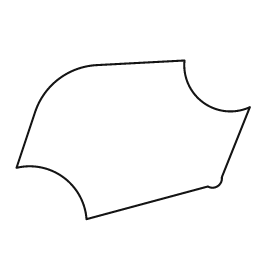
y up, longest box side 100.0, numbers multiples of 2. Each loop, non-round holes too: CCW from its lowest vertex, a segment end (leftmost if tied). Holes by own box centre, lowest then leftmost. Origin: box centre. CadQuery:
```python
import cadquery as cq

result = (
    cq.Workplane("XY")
    .moveTo(-20.0, -34.0)
    .lineTo(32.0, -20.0)
    .threePointArc((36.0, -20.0), (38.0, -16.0))
    .lineTo(50.0, 14.0)
    .threePointArc((30.0, 16.0), (22.0, 34.0))
    .lineTo(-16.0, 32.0)
    .threePointArc((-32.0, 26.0), (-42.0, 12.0))
    .lineTo(-50.0, -12.0)
    .threePointArc((-30.0, -16.0), (-20.0, -34.0))
    .close()
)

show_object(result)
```